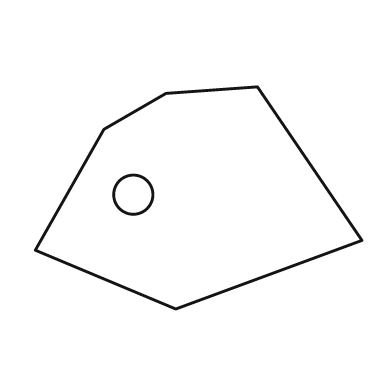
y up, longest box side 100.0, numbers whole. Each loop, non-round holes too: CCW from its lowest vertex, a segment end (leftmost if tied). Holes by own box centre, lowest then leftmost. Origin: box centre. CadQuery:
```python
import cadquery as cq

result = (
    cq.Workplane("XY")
    .moveTo(-7.0, -34.0)
    .lineTo(50.0, -13.0)
    .lineTo(18.0, 34.0)
    .lineTo(-10.0, 32.0)
    .lineTo(-29.0, 21.0)
    .lineTo(-50.0, -16.0)
    .close()
    .moveTo(-20.0, 1.0)
    .circle(6.0)
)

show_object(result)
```